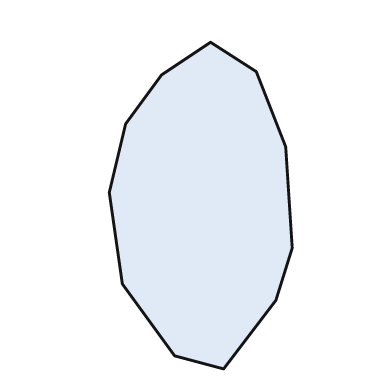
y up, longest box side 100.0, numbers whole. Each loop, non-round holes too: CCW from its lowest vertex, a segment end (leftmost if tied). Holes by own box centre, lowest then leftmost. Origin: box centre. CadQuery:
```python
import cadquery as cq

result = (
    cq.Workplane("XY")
    .moveTo(7.0, -50.0)
    .lineTo(23.0, -29.0)
    .lineTo(28.0, -13.0)
    .lineTo(26.0, 18.0)
    .lineTo(17.0, 41.0)
    .lineTo(3.0, 50.0)
    .lineTo(-12.0, 40.0)
    .lineTo(-23.0, 25.0)
    .lineTo(-28.0, 4.0)
    .lineTo(-24.0, -24.0)
    .lineTo(-8.0, -46.0)
    .close()
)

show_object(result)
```